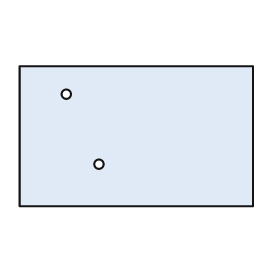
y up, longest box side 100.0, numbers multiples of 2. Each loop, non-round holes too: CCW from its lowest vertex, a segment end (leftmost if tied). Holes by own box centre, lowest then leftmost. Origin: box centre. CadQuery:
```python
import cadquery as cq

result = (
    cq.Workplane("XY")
    .moveTo(-50.0, -30.0)
    .lineTo(50.0, -30.0)
    .lineTo(50.0, 30.0)
    .lineTo(-50.0, 30.0)
    .close()
    .moveTo(-16.0, -12.0)
    .circle(2.0)
    .moveTo(-30.0, 18.0)
    .circle(2.0)
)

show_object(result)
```